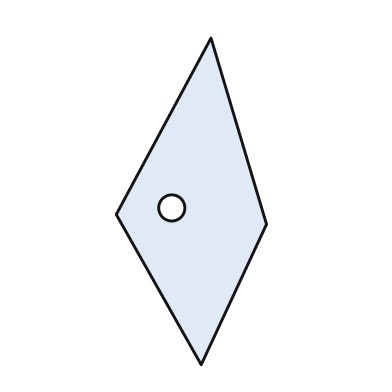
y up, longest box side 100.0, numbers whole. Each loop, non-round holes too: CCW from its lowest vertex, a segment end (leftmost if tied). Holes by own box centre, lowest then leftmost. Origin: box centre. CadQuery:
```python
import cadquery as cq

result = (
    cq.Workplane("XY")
    .moveTo(3.0, -50.0)
    .lineTo(23.0, -7.0)
    .lineTo(6.0, 50.0)
    .lineTo(-23.0, -4.0)
    .close()
    .moveTo(-6.0, -2.0)
    .circle(4.0)
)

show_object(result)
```